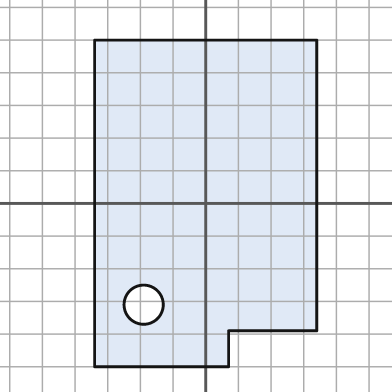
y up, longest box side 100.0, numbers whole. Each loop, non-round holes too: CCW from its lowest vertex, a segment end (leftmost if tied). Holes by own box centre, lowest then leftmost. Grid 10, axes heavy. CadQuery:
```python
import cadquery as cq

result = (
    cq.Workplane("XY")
    .moveTo(-34.0, -50.0)
    .lineTo(7.0, -50.0)
    .lineTo(7.0, -39.0)
    .lineTo(34.0, -39.0)
    .lineTo(34.0, 50.0)
    .lineTo(-34.0, 50.0)
    .close()
    .moveTo(-19.0, -31.0)
    .circle(6.0)
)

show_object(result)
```